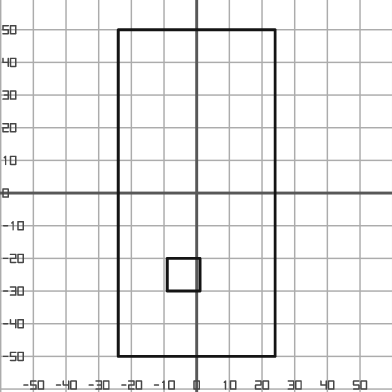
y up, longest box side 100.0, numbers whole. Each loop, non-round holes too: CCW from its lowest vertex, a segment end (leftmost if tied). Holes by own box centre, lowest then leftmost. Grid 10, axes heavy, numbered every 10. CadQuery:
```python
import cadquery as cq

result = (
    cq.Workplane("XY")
    .moveTo(-24.0, -50.0)
    .lineTo(24.0, -50.0)
    .lineTo(24.0, 50.0)
    .lineTo(-24.0, 50.0)
    .close()
    .moveTo(-9.0, -30.0)
    .lineTo(1.0, -30.0)
    .lineTo(1.0, -20.0)
    .lineTo(-9.0, -20.0)
    .close()
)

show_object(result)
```